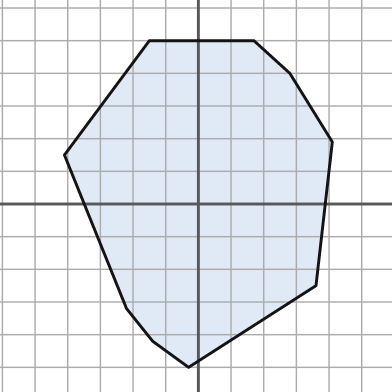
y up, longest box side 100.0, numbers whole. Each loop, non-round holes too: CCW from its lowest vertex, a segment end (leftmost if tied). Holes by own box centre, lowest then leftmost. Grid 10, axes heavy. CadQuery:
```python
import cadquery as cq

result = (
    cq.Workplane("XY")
    .moveTo(-3.0, -50.0)
    .lineTo(36.0, -25.0)
    .lineTo(41.0, 19.0)
    .lineTo(28.0, 40.0)
    .lineTo(17.0, 50.0)
    .lineTo(-15.0, 50.0)
    .lineTo(-41.0, 15.0)
    .lineTo(-22.0, -32.0)
    .lineTo(-14.0, -42.0)
    .close()
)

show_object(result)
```